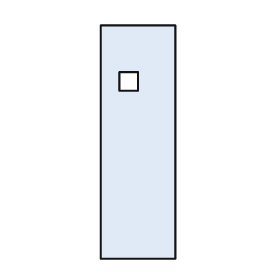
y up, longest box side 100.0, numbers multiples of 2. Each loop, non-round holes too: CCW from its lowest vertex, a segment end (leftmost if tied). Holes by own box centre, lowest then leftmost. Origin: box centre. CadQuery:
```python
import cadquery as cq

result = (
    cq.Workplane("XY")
    .moveTo(-16.0, -50.0)
    .lineTo(16.0, -50.0)
    .lineTo(16.0, 50.0)
    .lineTo(-16.0, 50.0)
    .close()
    .moveTo(-8.0, 22.0)
    .lineTo(0.0, 22.0)
    .lineTo(0.0, 30.0)
    .lineTo(-8.0, 30.0)
    .close()
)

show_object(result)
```